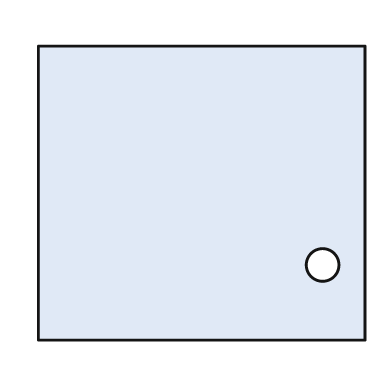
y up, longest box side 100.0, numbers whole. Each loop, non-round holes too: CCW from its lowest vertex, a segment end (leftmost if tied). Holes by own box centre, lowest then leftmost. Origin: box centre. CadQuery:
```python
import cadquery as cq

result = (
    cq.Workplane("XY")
    .moveTo(-50.0, -45.0)
    .lineTo(50.0, -45.0)
    .lineTo(50.0, 45.0)
    .lineTo(-50.0, 45.0)
    .close()
    .moveTo(37.0, -22.0)
    .circle(5.0)
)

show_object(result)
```